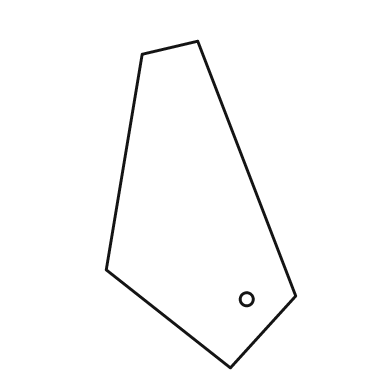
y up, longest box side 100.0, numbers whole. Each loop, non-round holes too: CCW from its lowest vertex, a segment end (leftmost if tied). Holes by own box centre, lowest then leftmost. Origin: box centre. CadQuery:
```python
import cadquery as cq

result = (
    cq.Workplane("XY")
    .moveTo(9.0, -50.0)
    .lineTo(29.0, -28.0)
    .lineTo(-1.0, 50.0)
    .lineTo(-18.0, 46.0)
    .lineTo(-29.0, -20.0)
    .close()
    .moveTo(14.0, -29.0)
    .circle(2.0)
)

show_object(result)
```